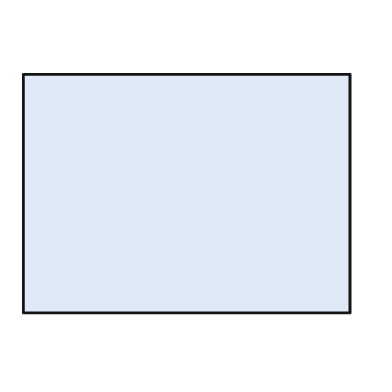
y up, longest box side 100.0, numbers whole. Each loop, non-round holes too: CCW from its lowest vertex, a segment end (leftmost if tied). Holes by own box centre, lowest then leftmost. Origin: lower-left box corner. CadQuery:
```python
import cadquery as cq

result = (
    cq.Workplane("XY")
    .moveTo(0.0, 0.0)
    .lineTo(100.0, 0.0)
    .lineTo(100.0, 73.0)
    .lineTo(0.0, 73.0)
    .close()
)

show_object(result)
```